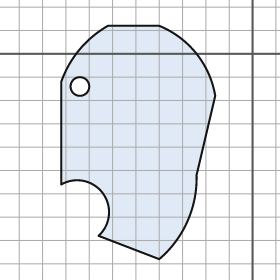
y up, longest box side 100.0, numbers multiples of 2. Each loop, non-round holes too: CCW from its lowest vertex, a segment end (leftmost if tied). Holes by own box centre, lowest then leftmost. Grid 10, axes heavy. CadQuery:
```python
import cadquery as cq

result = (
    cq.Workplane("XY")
    .moveTo(-40.0, -88.0)
    .threePointArc((-28.0, -72.0), (-24.0, -52.0))
    .lineTo(-16.0, -18.0)
    .threePointArc((-24.0, 0.0), (-40.0, 12.0))
    .lineTo(-62.0, 12.0)
    .threePointArc((-74.0, 2.0), (-82.0, -12.0))
    .lineTo(-82.0, -56.0)
    .threePointArc((-64.0, -60.0), (-66.0, -78.0))
    .close()
    .moveTo(-74.0, -14.0)
    .circle(4.0)
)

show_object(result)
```